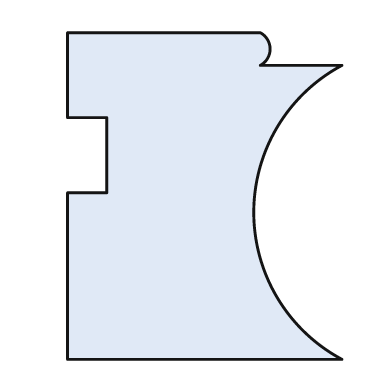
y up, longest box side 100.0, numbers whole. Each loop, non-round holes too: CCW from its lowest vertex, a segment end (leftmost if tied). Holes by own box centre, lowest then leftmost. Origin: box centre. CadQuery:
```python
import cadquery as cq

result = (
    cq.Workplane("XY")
    .moveTo(-42.0, -50.0)
    .lineTo(42.0, -50.0)
    .threePointArc((15.0, -5.0), (42.0, 40.0))
    .lineTo(17.0, 40.0)
    .threePointArc((20.0, 45.0), (17.0, 50.0))
    .lineTo(-42.0, 50.0)
    .lineTo(-42.0, 24.0)
    .lineTo(-30.0, 24.0)
    .lineTo(-30.0, 1.0)
    .lineTo(-42.0, 1.0)
    .close()
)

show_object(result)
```